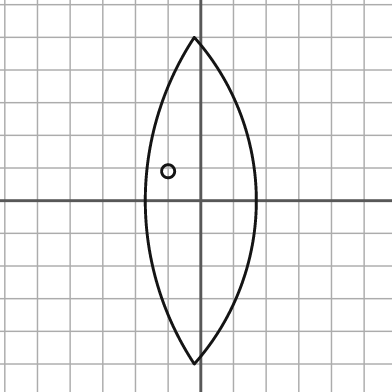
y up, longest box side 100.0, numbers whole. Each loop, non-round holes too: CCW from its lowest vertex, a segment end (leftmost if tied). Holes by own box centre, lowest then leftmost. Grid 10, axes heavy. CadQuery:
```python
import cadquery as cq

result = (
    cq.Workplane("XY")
    .moveTo(-2.0, -50.0)
    .threePointArc((17.0, 0.0), (-2.0, 50.0))
    .threePointArc((-17.0, 0.0), (-2.0, -50.0))
    .close()
    .moveTo(-10.0, 9.0)
    .circle(2.0)
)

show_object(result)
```